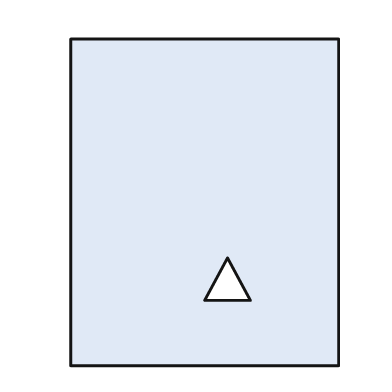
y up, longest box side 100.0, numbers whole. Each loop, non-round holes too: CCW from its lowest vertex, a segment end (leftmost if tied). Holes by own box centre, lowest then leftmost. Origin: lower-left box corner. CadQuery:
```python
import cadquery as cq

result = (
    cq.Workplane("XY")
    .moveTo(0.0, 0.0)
    .lineTo(82.0, 0.0)
    .lineTo(82.0, 100.0)
    .lineTo(0.0, 100.0)
    .close()
    .moveTo(41.0, 20.0)
    .lineTo(55.0, 20.0)
    .lineTo(48.0, 33.0)
    .close()
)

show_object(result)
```